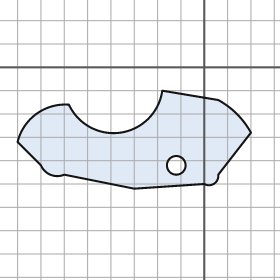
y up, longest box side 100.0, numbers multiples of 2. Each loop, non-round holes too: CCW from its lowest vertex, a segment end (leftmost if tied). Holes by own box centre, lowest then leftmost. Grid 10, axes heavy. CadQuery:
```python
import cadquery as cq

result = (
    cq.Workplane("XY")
    .moveTo(-30.0, -52.0)
    .lineTo(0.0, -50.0)
    .threePointArc((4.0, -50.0), (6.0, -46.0))
    .lineTo(20.0, -28.0)
    .threePointArc((14.0, -20.0), (6.0, -14.0))
    .lineTo(-18.0, -10.0)
    .threePointArc((-36.0, -28.0), (-58.0, -16.0))
    .threePointArc((-72.0, -20.0), (-80.0, -32.0))
    .lineTo(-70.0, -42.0)
    .threePointArc((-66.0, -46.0), (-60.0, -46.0))
    .close()
    .moveTo(-12.0, -42.0)
    .circle(4.0)
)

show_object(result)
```